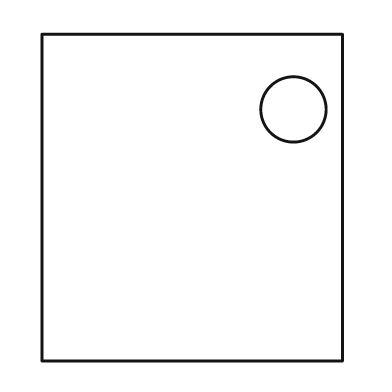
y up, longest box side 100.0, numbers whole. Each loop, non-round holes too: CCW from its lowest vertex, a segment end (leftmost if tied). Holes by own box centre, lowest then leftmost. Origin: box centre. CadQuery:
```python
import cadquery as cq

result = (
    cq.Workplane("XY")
    .moveTo(-46.0, -50.0)
    .lineTo(46.0, -50.0)
    .lineTo(46.0, 50.0)
    .lineTo(-46.0, 50.0)
    .close()
    .moveTo(31.0, 27.0)
    .circle(10.0)
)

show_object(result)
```